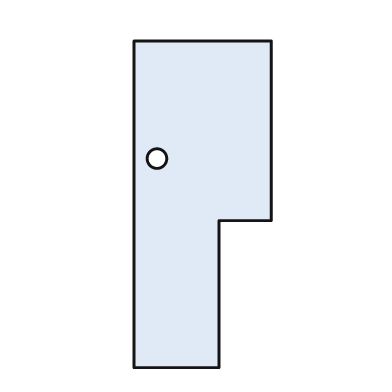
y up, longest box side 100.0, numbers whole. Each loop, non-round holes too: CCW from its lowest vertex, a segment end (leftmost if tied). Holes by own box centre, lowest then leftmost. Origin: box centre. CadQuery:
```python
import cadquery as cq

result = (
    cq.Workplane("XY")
    .moveTo(-21.0, -50.0)
    .lineTo(5.0, -50.0)
    .lineTo(5.0, -5.0)
    .lineTo(21.0, -5.0)
    .lineTo(21.0, 50.0)
    .lineTo(-21.0, 50.0)
    .close()
    .moveTo(-14.0, 14.0)
    .circle(3.0)
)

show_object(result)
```